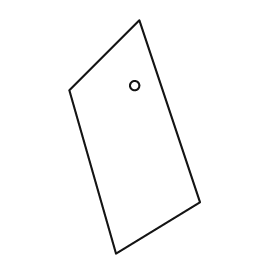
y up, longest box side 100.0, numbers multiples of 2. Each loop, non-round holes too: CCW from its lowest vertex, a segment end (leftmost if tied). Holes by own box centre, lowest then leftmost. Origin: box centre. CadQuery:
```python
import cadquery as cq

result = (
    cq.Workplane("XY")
    .moveTo(-8.0, -50.0)
    .lineTo(28.0, -28.0)
    .lineTo(2.0, 50.0)
    .lineTo(-28.0, 20.0)
    .close()
    .moveTo(0.0, 22.0)
    .circle(2.0)
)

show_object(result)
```